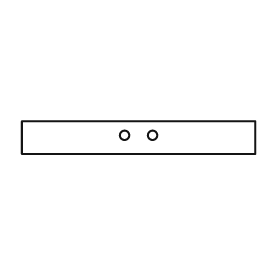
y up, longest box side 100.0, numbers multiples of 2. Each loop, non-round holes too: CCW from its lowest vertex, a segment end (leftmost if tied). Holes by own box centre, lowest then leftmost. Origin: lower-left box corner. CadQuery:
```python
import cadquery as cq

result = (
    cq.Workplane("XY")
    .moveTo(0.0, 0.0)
    .lineTo(100.0, 0.0)
    .lineTo(100.0, 14.0)
    .lineTo(0.0, 14.0)
    .close()
    .moveTo(44.0, 8.0)
    .circle(2.0)
    .moveTo(56.0, 8.0)
    .circle(2.0)
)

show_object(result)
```